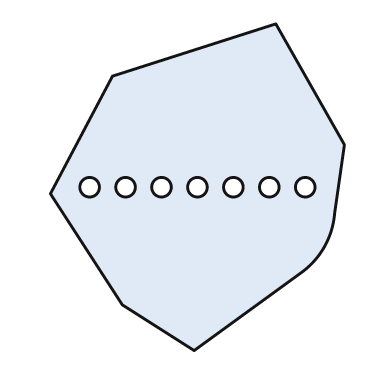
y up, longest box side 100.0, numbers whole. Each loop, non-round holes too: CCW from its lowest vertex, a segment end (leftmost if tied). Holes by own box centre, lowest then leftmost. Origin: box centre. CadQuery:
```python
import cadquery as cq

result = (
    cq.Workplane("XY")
    .moveTo(-1.0, -50.0)
    .lineTo(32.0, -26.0)
    .threePointArc((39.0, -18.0), (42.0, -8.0))
    .lineTo(45.0, 13.0)
    .lineTo(24.0, 50.0)
    .lineTo(-26.0, 34.0)
    .lineTo(-45.0, -2.0)
    .lineTo(-23.0, -36.0)
    .close()
    .moveTo(-33.0, 0.0)
    .circle(3.0)
    .moveTo(-22.0, 0.0)
    .circle(3.0)
    .moveTo(-11.0, 0.0)
    .circle(3.0)
    .moveTo(0.0, 0.0)
    .circle(3.0)
    .moveTo(11.0, 0.0)
    .circle(3.0)
    .moveTo(22.0, 0.0)
    .circle(3.0)
    .moveTo(33.0, 0.0)
    .circle(3.0)
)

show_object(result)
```